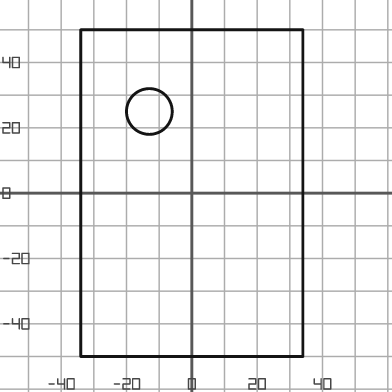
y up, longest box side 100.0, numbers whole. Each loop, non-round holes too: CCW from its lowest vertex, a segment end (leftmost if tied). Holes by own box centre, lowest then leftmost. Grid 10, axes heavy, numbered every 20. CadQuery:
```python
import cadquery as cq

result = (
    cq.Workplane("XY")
    .moveTo(-34.0, -50.0)
    .lineTo(34.0, -50.0)
    .lineTo(34.0, 50.0)
    .lineTo(-34.0, 50.0)
    .close()
    .moveTo(-13.0, 25.0)
    .circle(7.0)
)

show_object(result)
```